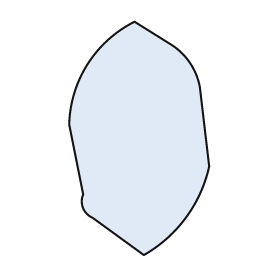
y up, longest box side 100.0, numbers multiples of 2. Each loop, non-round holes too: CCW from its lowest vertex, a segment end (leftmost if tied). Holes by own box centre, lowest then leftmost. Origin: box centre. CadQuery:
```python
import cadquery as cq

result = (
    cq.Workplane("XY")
    .moveTo(2.0, -50.0)
    .threePointArc((20.0, -34.0), (30.0, -12.0))
    .lineTo(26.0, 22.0)
    .threePointArc((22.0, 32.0), (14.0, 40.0))
    .lineTo(-2.0, 50.0)
    .threePointArc((-22.0, 32.0), (-30.0, 6.0))
    .lineTo(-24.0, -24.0)
    .threePointArc((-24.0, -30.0), (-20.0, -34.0))
    .close()
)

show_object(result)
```